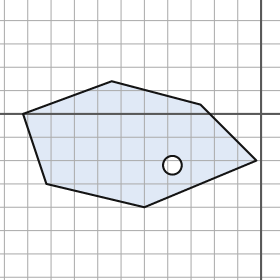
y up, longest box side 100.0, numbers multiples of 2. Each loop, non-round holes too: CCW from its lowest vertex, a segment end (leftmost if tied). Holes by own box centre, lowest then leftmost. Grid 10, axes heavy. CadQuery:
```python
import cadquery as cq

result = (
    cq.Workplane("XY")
    .moveTo(-50.0, -40.0)
    .lineTo(-2.0, -20.0)
    .lineTo(-26.0, 4.0)
    .lineTo(-64.0, 14.0)
    .lineTo(-102.0, 0.0)
    .lineTo(-92.0, -30.0)
    .close()
    .moveTo(-38.0, -22.0)
    .circle(4.0)
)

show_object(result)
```